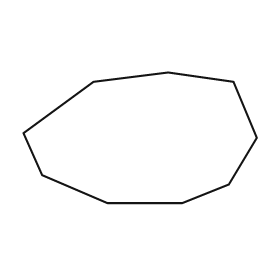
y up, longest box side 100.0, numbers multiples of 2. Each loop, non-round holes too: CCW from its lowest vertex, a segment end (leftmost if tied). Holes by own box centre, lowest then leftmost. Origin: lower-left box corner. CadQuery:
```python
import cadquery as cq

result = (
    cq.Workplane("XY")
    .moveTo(36.0, 0.0)
    .lineTo(68.0, 0.0)
    .lineTo(88.0, 8.0)
    .lineTo(100.0, 28.0)
    .lineTo(90.0, 52.0)
    .lineTo(62.0, 56.0)
    .lineTo(30.0, 52.0)
    .lineTo(0.0, 30.0)
    .lineTo(8.0, 12.0)
    .close()
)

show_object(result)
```